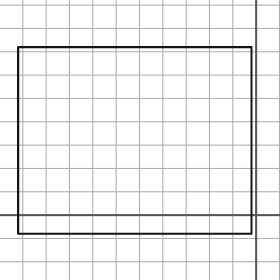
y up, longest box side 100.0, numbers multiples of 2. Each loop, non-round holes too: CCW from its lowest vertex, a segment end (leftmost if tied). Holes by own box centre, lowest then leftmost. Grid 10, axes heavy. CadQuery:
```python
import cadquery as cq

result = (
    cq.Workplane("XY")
    .moveTo(-102.0, -8.0)
    .lineTo(-2.0, -8.0)
    .lineTo(-2.0, 72.0)
    .lineTo(-102.0, 72.0)
    .close()
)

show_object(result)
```